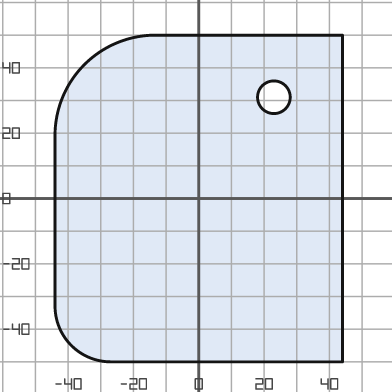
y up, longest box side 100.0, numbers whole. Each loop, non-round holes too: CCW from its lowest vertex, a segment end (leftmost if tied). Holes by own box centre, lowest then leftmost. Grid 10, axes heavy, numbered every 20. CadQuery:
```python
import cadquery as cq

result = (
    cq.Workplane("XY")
    .moveTo(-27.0, -50.0)
    .lineTo(44.0, -50.0)
    .lineTo(44.0, 50.0)
    .lineTo(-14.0, 50.0)
    .threePointArc((-35.0, 41.0), (-44.0, 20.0))
    .lineTo(-44.0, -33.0)
    .threePointArc((-39.0, -45.0), (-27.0, -50.0))
    .close()
    .moveTo(23.0, 31.0)
    .circle(5.0)
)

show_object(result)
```